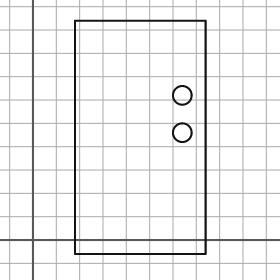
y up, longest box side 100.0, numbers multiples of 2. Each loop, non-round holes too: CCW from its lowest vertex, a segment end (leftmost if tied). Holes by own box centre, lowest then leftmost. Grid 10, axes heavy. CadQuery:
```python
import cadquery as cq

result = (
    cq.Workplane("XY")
    .moveTo(18.0, -6.0)
    .lineTo(74.0, -6.0)
    .lineTo(74.0, 94.0)
    .lineTo(18.0, 94.0)
    .close()
    .moveTo(64.0, 46.0)
    .circle(4.0)
    .moveTo(64.0, 62.0)
    .circle(4.0)
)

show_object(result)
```